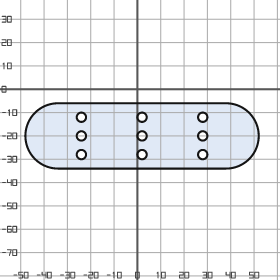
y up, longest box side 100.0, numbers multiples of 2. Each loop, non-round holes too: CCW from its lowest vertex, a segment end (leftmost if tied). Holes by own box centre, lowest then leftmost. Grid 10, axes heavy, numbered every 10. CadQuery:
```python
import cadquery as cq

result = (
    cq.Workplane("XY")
    .moveTo(-34.0, -34.0)
    .lineTo(38.0, -34.0)
    .threePointArc((52.0, -20.0), (38.0, -6.0))
    .lineTo(-34.0, -6.0)
    .threePointArc((-48.0, -20.0), (-34.0, -34.0))
    .close()
    .moveTo(-24.0, -28.0)
    .circle(2.0)
    .moveTo(2.0, -28.0)
    .circle(2.0)
    .moveTo(28.0, -28.0)
    .circle(2.0)
    .moveTo(-24.0, -20.0)
    .circle(2.0)
    .moveTo(2.0, -20.0)
    .circle(2.0)
    .moveTo(28.0, -20.0)
    .circle(2.0)
    .moveTo(-24.0, -12.0)
    .circle(2.0)
    .moveTo(2.0, -12.0)
    .circle(2.0)
    .moveTo(28.0, -12.0)
    .circle(2.0)
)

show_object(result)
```